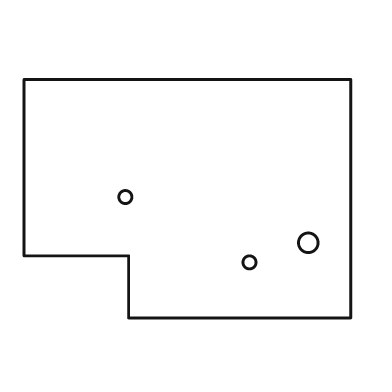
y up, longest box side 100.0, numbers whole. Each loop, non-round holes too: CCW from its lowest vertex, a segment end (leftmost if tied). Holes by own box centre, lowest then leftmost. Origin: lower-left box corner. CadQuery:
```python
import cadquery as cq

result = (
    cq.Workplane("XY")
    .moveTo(32.0, 0.0)
    .lineTo(100.0, 0.0)
    .lineTo(100.0, 73.0)
    .lineTo(0.0, 73.0)
    .lineTo(0.0, 19.0)
    .lineTo(32.0, 19.0)
    .close()
    .moveTo(69.0, 17.0)
    .circle(2.0)
    .moveTo(87.0, 23.0)
    .circle(3.0)
    .moveTo(31.0, 37.0)
    .circle(2.0)
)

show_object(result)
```